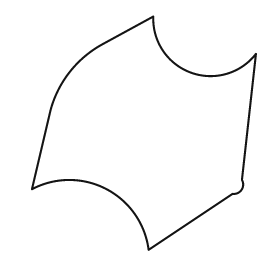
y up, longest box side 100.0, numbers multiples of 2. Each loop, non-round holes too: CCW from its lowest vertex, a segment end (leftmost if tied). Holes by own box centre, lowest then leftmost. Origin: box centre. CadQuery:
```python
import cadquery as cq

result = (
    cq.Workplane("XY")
    .moveTo(2.0, -50.0)
    .lineTo(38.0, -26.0)
    .threePointArc((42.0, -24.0), (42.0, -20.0))
    .lineTo(48.0, 34.0)
    .threePointArc((20.0, 26.0), (4.0, 50.0))
    .lineTo(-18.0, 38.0)
    .threePointArc((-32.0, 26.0), (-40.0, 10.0))
    .lineTo(-48.0, -24.0)
    .threePointArc((-16.0, -24.0), (2.0, -50.0))
    .close()
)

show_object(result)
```